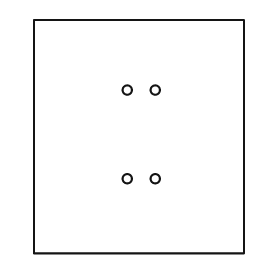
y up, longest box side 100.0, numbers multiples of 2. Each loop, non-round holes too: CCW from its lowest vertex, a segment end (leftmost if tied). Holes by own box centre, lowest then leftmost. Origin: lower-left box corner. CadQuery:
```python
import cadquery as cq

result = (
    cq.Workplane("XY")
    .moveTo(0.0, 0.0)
    .lineTo(90.0, 0.0)
    .lineTo(90.0, 100.0)
    .lineTo(0.0, 100.0)
    .close()
    .moveTo(40.0, 32.0)
    .circle(2.0)
    .moveTo(52.0, 32.0)
    .circle(2.0)
    .moveTo(40.0, 70.0)
    .circle(2.0)
    .moveTo(52.0, 70.0)
    .circle(2.0)
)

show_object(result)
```